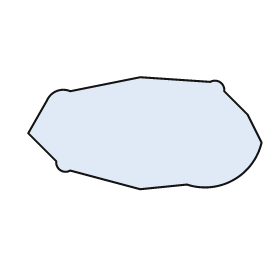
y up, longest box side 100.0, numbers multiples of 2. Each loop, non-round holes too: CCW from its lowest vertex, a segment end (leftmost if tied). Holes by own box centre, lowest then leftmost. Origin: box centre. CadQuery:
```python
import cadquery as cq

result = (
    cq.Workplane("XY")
    .moveTo(-2.0, -24.0)
    .lineTo(18.0, -22.0)
    .threePointArc((38.0, -20.0), (50.0, -4.0))
    .lineTo(44.0, 8.0)
    .lineTo(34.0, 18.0)
    .threePointArc((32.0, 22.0), (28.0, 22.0))
    .lineTo(-2.0, 24.0)
    .lineTo(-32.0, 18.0)
    .threePointArc((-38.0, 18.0), (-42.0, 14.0))
    .lineTo(-50.0, 0.0)
    .lineTo(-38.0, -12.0)
    .threePointArc((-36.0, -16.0), (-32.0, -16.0))
    .close()
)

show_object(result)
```